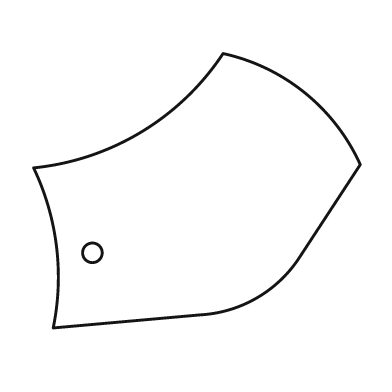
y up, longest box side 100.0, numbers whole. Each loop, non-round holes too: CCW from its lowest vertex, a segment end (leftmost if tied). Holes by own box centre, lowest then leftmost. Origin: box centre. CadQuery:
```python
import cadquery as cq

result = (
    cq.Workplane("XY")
    .moveTo(-44.0, -42.0)
    .lineTo(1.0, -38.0)
    .threePointArc((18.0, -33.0), (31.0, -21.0))
    .lineTo(50.0, 8.0)
    .threePointArc((33.0, 30.0), (8.0, 42.0))
    .threePointArc((-17.0, 18.0), (-50.0, 7.0))
    .threePointArc((-43.0, -17.0), (-44.0, -42.0))
    .close()
    .moveTo(-32.0, -19.0)
    .circle(3.0)
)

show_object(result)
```